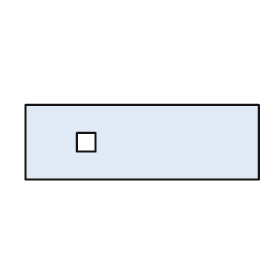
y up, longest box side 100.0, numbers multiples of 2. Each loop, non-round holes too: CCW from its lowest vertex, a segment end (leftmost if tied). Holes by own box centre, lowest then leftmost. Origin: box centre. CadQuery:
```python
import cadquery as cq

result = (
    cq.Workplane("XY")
    .moveTo(-50.0, -16.0)
    .lineTo(50.0, -16.0)
    .lineTo(50.0, 16.0)
    .lineTo(-50.0, 16.0)
    .close()
    .moveTo(-28.0, -4.0)
    .lineTo(-20.0, -4.0)
    .lineTo(-20.0, 4.0)
    .lineTo(-28.0, 4.0)
    .close()
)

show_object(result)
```